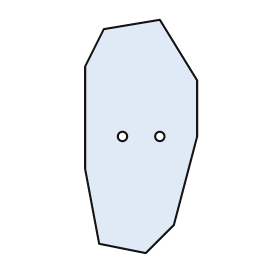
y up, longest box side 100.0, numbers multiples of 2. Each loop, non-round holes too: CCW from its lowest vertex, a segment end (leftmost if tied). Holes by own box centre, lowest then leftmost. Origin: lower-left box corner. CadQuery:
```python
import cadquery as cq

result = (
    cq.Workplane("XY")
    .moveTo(26.0, 0.0)
    .lineTo(38.0, 12.0)
    .lineTo(48.0, 50.0)
    .lineTo(48.0, 74.0)
    .lineTo(32.0, 100.0)
    .lineTo(8.0, 96.0)
    .lineTo(0.0, 80.0)
    .lineTo(0.0, 36.0)
    .lineTo(6.0, 4.0)
    .close()
    .moveTo(16.0, 50.0)
    .circle(2.0)
    .moveTo(32.0, 50.0)
    .circle(2.0)
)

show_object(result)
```